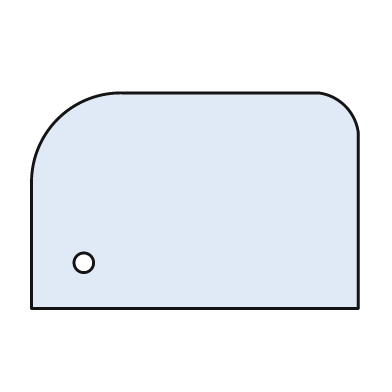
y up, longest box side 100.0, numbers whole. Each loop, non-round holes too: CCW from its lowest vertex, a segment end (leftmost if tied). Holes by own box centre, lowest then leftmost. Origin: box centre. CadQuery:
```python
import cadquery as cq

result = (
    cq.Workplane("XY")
    .moveTo(-50.0, -33.0)
    .lineTo(50.0, -33.0)
    .lineTo(50.0, 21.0)
    .threePointArc((46.0, 29.0), (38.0, 33.0))
    .lineTo(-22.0, 33.0)
    .threePointArc((-42.0, 25.0), (-50.0, 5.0))
    .close()
    .moveTo(-34.0, -19.0)
    .circle(3.0)
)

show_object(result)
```